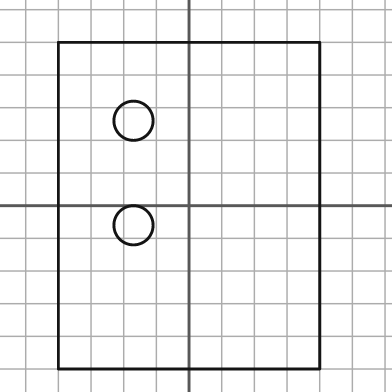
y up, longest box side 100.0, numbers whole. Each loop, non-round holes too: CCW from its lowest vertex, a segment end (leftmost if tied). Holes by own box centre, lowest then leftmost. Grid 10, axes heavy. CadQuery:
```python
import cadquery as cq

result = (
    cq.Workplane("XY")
    .moveTo(-40.0, -50.0)
    .lineTo(40.0, -50.0)
    .lineTo(40.0, 50.0)
    .lineTo(-40.0, 50.0)
    .close()
    .moveTo(-17.0, -6.0)
    .circle(6.0)
    .moveTo(-17.0, 26.0)
    .circle(6.0)
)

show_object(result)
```